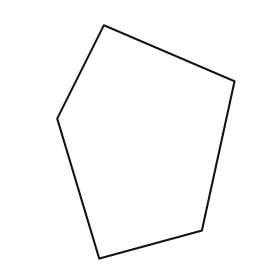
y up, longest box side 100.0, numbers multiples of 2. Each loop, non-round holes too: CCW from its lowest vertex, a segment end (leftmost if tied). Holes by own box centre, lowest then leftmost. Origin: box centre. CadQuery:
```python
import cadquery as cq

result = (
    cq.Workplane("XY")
    .moveTo(-20.0, -50.0)
    .lineTo(24.0, -38.0)
    .lineTo(38.0, 26.0)
    .lineTo(-18.0, 50.0)
    .lineTo(-38.0, 10.0)
    .close()
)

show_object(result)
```